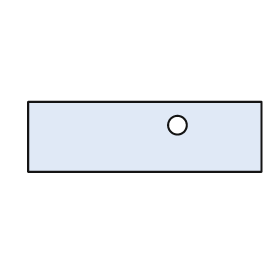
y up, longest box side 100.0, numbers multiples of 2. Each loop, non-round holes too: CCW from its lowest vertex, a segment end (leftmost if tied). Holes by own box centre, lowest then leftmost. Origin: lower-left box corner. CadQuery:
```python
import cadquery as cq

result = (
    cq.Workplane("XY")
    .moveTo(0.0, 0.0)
    .lineTo(100.0, 0.0)
    .lineTo(100.0, 30.0)
    .lineTo(0.0, 30.0)
    .close()
    .moveTo(64.0, 20.0)
    .circle(4.0)
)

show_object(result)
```